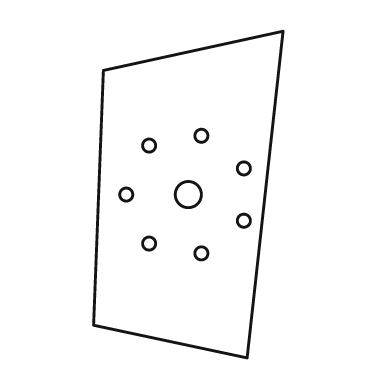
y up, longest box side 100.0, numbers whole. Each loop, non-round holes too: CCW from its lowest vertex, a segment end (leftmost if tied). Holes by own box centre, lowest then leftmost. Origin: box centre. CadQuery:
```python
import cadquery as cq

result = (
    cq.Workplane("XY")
    .moveTo(18.0, -50.0)
    .lineTo(29.0, 50.0)
    .lineTo(-26.0, 38.0)
    .lineTo(-29.0, -40.0)
    .close()
    .moveTo(4.0, -18.0)
    .circle(2.0)
    .moveTo(-12.0, -15.0)
    .circle(2.0)
    .moveTo(17.0, -8.0)
    .circle(2.0)
    .moveTo(-19.0, 0.0)
    .circle(2.0)
    .moveTo(0.0, 0.0)
    .circle(4.0)
    .moveTo(17.0, 8.0)
    .circle(2.0)
    .moveTo(-12.0, 15.0)
    .circle(2.0)
    .moveTo(4.0, 18.0)
    .circle(2.0)
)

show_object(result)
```